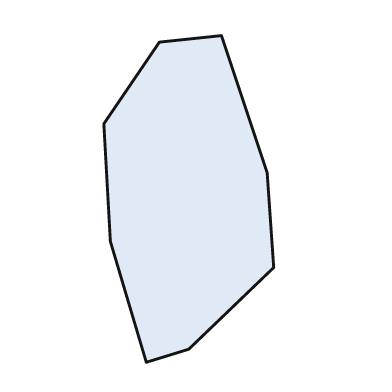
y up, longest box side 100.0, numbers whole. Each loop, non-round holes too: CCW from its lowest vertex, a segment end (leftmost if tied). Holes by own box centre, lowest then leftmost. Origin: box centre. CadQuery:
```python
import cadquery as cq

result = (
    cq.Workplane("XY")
    .moveTo(-13.0, -50.0)
    .lineTo(0.0, -46.0)
    .lineTo(26.0, -21.0)
    .lineTo(24.0, 8.0)
    .lineTo(10.0, 50.0)
    .lineTo(-9.0, 48.0)
    .lineTo(-26.0, 23.0)
    .lineTo(-24.0, -13.0)
    .close()
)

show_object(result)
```